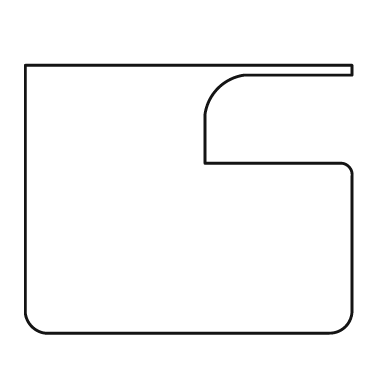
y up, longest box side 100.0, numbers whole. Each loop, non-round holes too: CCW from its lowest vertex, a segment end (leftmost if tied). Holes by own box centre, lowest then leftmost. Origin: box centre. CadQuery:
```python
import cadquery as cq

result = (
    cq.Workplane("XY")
    .moveTo(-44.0, -41.0)
    .lineTo(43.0, -41.0)
    .threePointArc((48.0, -39.0), (50.0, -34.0))
    .lineTo(50.0, 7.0)
    .threePointArc((49.0, 10.0), (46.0, 11.0))
    .lineTo(5.0, 11.0)
    .lineTo(5.0, 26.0)
    .threePointArc((9.0, 34.0), (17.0, 38.0))
    .lineTo(50.0, 38.0)
    .lineTo(50.0, 41.0)
    .lineTo(-50.0, 41.0)
    .lineTo(-50.0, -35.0)
    .threePointArc((-48.0, -39.0), (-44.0, -41.0))
    .close()
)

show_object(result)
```